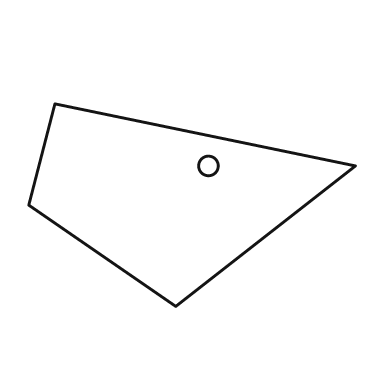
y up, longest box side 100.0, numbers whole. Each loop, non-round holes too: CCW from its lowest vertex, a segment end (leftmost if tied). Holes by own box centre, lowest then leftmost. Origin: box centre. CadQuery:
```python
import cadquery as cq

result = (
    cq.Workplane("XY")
    .moveTo(-5.0, -31.0)
    .lineTo(50.0, 12.0)
    .lineTo(-42.0, 31.0)
    .lineTo(-50.0, 0.0)
    .close()
    .moveTo(5.0, 12.0)
    .circle(3.0)
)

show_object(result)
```